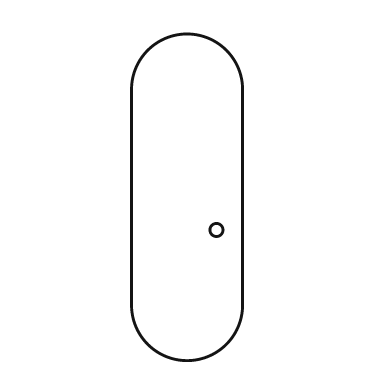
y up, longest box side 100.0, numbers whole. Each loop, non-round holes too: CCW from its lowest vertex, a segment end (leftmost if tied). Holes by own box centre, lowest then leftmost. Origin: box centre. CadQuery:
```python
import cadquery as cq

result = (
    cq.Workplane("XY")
    .moveTo(-17.0, -33.0)
    .threePointArc((0.0, -50.0), (17.0, -33.0))
    .lineTo(17.0, 33.0)
    .threePointArc((0.0, 50.0), (-17.0, 33.0))
    .close()
    .moveTo(9.0, -10.0)
    .circle(2.0)
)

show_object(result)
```